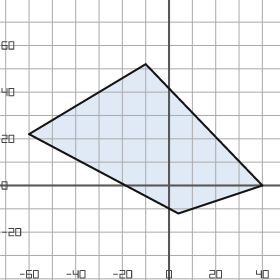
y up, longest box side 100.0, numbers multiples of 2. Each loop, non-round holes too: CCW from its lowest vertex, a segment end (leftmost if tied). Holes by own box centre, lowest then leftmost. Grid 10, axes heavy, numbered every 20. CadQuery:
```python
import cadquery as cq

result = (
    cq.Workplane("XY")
    .moveTo(4.0, -12.0)
    .lineTo(40.0, 0.0)
    .lineTo(-10.0, 52.0)
    .lineTo(-60.0, 22.0)
    .close()
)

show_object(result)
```